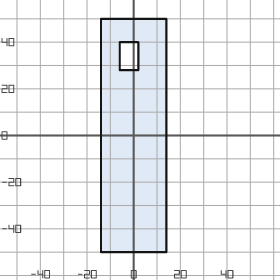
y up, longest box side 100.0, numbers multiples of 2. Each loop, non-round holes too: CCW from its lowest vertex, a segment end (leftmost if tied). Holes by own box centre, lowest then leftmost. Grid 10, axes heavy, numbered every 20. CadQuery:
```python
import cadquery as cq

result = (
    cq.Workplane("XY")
    .moveTo(-14.0, -50.0)
    .lineTo(14.0, -50.0)
    .lineTo(14.0, 50.0)
    .lineTo(-14.0, 50.0)
    .close()
    .moveTo(-6.0, 28.0)
    .lineTo(2.0, 28.0)
    .lineTo(2.0, 40.0)
    .lineTo(-6.0, 40.0)
    .close()
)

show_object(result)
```